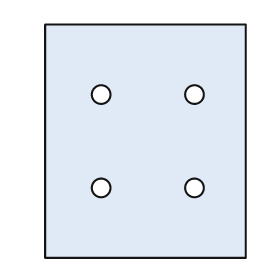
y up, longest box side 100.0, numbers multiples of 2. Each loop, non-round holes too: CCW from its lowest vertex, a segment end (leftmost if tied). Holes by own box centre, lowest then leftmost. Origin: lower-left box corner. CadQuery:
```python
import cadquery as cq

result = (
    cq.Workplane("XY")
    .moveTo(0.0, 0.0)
    .lineTo(86.0, 0.0)
    .lineTo(86.0, 100.0)
    .lineTo(0.0, 100.0)
    .close()
    .moveTo(24.0, 30.0)
    .circle(4.0)
    .moveTo(64.0, 30.0)
    .circle(4.0)
    .moveTo(24.0, 70.0)
    .circle(4.0)
    .moveTo(64.0, 70.0)
    .circle(4.0)
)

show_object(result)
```